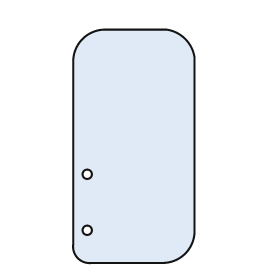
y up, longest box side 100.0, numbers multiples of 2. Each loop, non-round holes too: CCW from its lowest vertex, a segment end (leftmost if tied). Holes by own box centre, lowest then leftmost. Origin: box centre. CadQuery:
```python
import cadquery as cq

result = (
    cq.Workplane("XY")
    .moveTo(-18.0, -50.0)
    .lineTo(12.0, -50.0)
    .threePointArc((22.0, -46.0), (26.0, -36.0))
    .lineTo(26.0, 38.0)
    .threePointArc((22.0, 46.0), (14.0, 50.0))
    .lineTo(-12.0, 50.0)
    .threePointArc((-22.0, 46.0), (-26.0, 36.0))
    .lineTo(-26.0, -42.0)
    .threePointArc((-24.0, -48.0), (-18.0, -50.0))
    .close()
    .moveTo(-20.0, -36.0)
    .circle(2.0)
    .moveTo(-20.0, -12.0)
    .circle(2.0)
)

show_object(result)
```